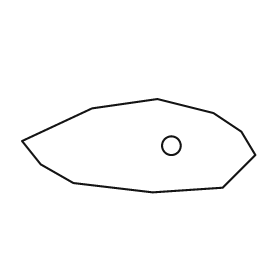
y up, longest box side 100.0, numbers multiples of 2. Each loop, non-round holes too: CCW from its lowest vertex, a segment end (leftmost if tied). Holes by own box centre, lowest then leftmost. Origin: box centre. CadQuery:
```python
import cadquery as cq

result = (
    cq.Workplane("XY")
    .moveTo(6.0, -20.0)
    .lineTo(36.0, -18.0)
    .lineTo(50.0, -4.0)
    .lineTo(44.0, 6.0)
    .lineTo(32.0, 14.0)
    .lineTo(8.0, 20.0)
    .lineTo(-20.0, 16.0)
    .lineTo(-50.0, 2.0)
    .lineTo(-42.0, -8.0)
    .lineTo(-28.0, -16.0)
    .close()
    .moveTo(14.0, 0.0)
    .circle(4.0)
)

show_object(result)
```